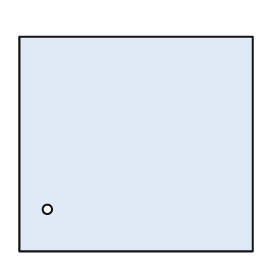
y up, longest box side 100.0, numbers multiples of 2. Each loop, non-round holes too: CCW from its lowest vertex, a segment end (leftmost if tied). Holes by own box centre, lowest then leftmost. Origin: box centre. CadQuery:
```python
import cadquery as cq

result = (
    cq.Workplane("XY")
    .moveTo(-50.0, -46.0)
    .lineTo(50.0, -46.0)
    .lineTo(50.0, 46.0)
    .lineTo(-50.0, 46.0)
    .close()
    .moveTo(-38.0, -28.0)
    .circle(2.0)
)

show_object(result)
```